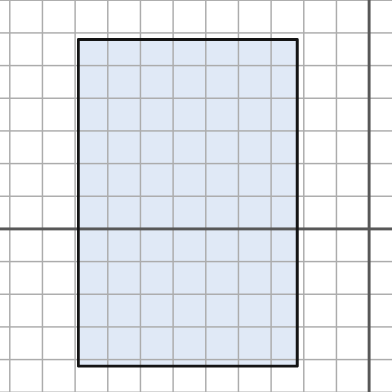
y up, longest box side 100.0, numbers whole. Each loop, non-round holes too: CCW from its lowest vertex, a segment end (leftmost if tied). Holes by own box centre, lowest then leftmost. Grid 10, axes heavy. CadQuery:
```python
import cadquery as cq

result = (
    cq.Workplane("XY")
    .moveTo(-89.0, -42.0)
    .lineTo(-22.0, -42.0)
    .lineTo(-22.0, 58.0)
    .lineTo(-89.0, 58.0)
    .close()
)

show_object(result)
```